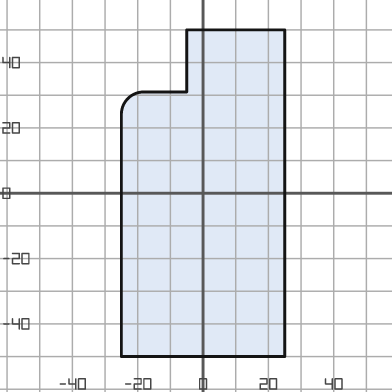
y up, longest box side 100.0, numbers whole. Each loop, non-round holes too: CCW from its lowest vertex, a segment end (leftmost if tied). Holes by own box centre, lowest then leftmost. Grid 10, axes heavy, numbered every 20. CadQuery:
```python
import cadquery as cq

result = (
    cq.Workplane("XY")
    .moveTo(-25.0, -50.0)
    .lineTo(25.0, -50.0)
    .lineTo(25.0, 50.0)
    .lineTo(-5.0, 50.0)
    .lineTo(-5.0, 31.0)
    .lineTo(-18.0, 31.0)
    .threePointArc((-23.0, 29.0), (-25.0, 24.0))
    .close()
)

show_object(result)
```